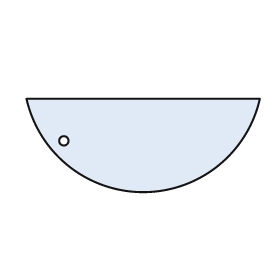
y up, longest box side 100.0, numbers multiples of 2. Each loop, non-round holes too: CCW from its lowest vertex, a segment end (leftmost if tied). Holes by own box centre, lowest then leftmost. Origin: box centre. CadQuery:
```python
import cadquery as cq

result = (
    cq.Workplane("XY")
    .moveTo(-50.0, 20.0)
    .threePointArc((0.0, -20.0), (50.0, 20.0))
    .close()
    .moveTo(-34.0, 2.0)
    .circle(2.0)
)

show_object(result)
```